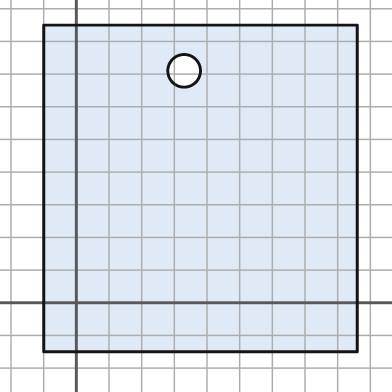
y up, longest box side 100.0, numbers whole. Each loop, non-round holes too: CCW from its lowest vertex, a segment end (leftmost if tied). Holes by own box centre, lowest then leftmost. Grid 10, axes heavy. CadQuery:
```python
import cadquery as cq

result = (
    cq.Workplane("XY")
    .moveTo(-10.0, -15.0)
    .lineTo(86.0, -15.0)
    .lineTo(86.0, 85.0)
    .lineTo(-10.0, 85.0)
    .close()
    .moveTo(33.0, 71.0)
    .circle(5.0)
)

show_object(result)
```